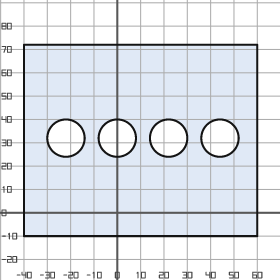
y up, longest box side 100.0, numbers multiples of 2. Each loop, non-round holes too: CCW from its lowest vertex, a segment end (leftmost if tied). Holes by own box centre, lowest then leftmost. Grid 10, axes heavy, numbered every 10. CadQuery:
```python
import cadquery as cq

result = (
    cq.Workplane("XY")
    .moveTo(-40.0, -10.0)
    .lineTo(60.0, -10.0)
    .lineTo(60.0, 72.0)
    .lineTo(-40.0, 72.0)
    .close()
    .moveTo(-22.0, 32.0)
    .circle(8.0)
    .moveTo(0.0, 32.0)
    .circle(8.0)
    .moveTo(22.0, 32.0)
    .circle(8.0)
    .moveTo(44.0, 32.0)
    .circle(8.0)
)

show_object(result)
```